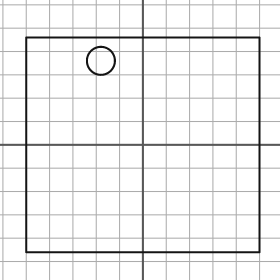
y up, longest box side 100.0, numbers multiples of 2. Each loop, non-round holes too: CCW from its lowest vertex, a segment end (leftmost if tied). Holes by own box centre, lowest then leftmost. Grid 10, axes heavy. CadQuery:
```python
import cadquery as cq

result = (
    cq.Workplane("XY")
    .moveTo(-50.0, -46.0)
    .lineTo(50.0, -46.0)
    .lineTo(50.0, 46.0)
    .lineTo(-50.0, 46.0)
    .close()
    .moveTo(-18.0, 36.0)
    .circle(6.0)
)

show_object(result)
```